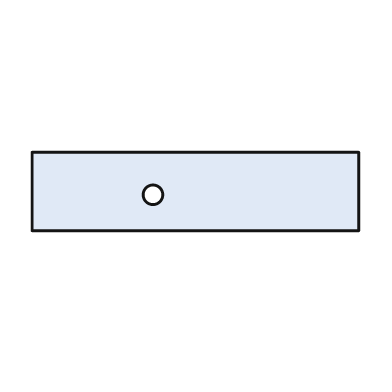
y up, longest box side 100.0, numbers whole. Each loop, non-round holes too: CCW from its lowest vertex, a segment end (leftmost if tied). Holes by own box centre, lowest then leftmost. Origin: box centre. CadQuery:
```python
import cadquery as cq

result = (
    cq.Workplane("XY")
    .moveTo(-50.0, -12.0)
    .lineTo(50.0, -12.0)
    .lineTo(50.0, 12.0)
    .lineTo(-50.0, 12.0)
    .close()
    .moveTo(-13.0, -1.0)
    .circle(3.0)
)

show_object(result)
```